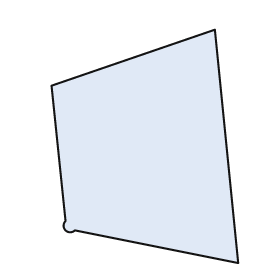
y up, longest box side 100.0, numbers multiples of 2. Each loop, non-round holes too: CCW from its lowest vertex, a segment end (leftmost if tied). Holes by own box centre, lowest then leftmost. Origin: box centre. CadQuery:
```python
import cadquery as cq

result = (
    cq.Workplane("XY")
    .moveTo(40.0, -50.0)
    .lineTo(30.0, 50.0)
    .lineTo(-40.0, 26.0)
    .lineTo(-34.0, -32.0)
    .threePointArc((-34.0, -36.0), (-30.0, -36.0))
    .close()
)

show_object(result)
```